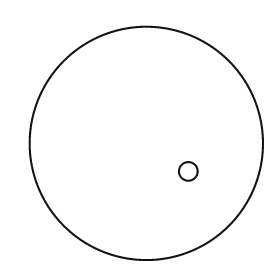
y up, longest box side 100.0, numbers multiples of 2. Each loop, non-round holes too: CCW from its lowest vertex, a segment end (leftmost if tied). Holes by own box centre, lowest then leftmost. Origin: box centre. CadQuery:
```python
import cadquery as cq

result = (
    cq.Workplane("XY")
    .moveTo(0.0, 0.0)
    .circle(50.0)
    .moveTo(18.0, -12.0)
    .circle(4.0)
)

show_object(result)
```